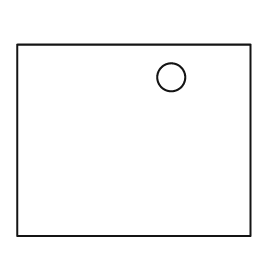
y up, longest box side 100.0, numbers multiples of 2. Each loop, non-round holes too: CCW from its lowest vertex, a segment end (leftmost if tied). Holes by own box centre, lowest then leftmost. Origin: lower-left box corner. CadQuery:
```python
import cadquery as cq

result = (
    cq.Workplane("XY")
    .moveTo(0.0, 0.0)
    .lineTo(100.0, 0.0)
    .lineTo(100.0, 82.0)
    .lineTo(0.0, 82.0)
    .close()
    .moveTo(66.0, 68.0)
    .circle(6.0)
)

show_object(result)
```